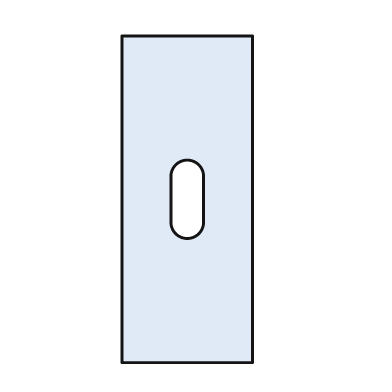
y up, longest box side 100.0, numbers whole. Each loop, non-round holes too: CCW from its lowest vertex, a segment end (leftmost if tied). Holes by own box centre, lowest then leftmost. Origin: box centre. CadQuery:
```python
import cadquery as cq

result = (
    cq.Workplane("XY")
    .moveTo(-20.0, -50.0)
    .lineTo(20.0, -50.0)
    .lineTo(20.0, 50.0)
    .lineTo(-20.0, 50.0)
    .close()
    .moveTo(-5.0, -7.0)
    .threePointArc((0.0, -12.0), (5.0, -7.0))
    .lineTo(5.0, 7.0)
    .threePointArc((0.0, 12.0), (-5.0, 7.0))
    .close()
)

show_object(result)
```